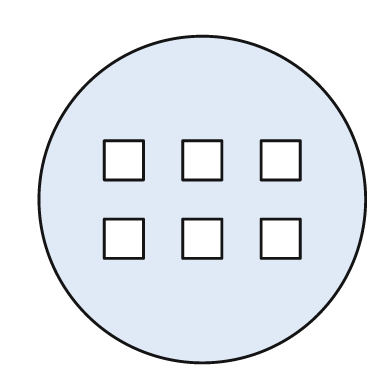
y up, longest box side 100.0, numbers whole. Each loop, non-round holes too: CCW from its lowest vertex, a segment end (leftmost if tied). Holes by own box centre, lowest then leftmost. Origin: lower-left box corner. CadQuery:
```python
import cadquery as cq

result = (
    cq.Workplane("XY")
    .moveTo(50.0, 50.0)
    .circle(50.0)
    .moveTo(20.0, 32.0)
    .lineTo(32.0, 32.0)
    .lineTo(32.0, 44.0)
    .lineTo(20.0, 44.0)
    .close()
    .moveTo(44.0, 32.0)
    .lineTo(56.0, 32.0)
    .lineTo(56.0, 44.0)
    .lineTo(44.0, 44.0)
    .close()
    .moveTo(68.0, 32.0)
    .lineTo(80.0, 32.0)
    .lineTo(80.0, 44.0)
    .lineTo(68.0, 44.0)
    .close()
    .moveTo(20.0, 56.0)
    .lineTo(32.0, 56.0)
    .lineTo(32.0, 68.0)
    .lineTo(20.0, 68.0)
    .close()
    .moveTo(44.0, 56.0)
    .lineTo(56.0, 56.0)
    .lineTo(56.0, 68.0)
    .lineTo(44.0, 68.0)
    .close()
    .moveTo(68.0, 56.0)
    .lineTo(80.0, 56.0)
    .lineTo(80.0, 68.0)
    .lineTo(68.0, 68.0)
    .close()
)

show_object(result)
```